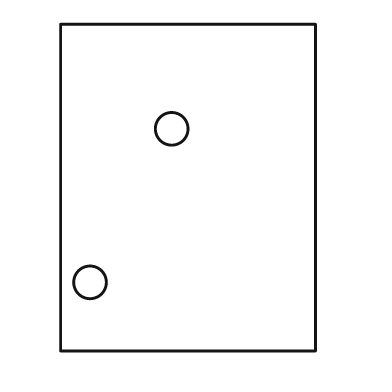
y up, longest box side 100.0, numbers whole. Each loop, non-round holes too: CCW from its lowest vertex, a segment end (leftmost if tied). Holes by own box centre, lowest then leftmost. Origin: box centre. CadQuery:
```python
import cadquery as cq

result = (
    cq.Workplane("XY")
    .moveTo(-39.0, -50.0)
    .lineTo(39.0, -50.0)
    .lineTo(39.0, 50.0)
    .lineTo(-39.0, 50.0)
    .close()
    .moveTo(-30.0, -29.0)
    .circle(5.0)
    .moveTo(-5.0, 18.0)
    .circle(5.0)
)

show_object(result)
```